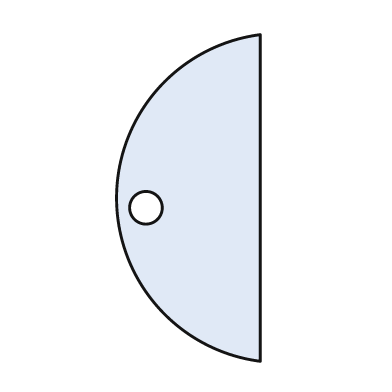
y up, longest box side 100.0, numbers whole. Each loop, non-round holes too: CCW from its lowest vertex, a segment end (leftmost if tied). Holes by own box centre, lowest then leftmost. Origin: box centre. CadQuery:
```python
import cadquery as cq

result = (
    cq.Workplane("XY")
    .moveTo(22.0, -50.0)
    .lineTo(22.0, 50.0)
    .threePointArc((-22.0, 0.0), (22.0, -50.0))
    .close()
    .moveTo(-13.0, -3.0)
    .circle(5.0)
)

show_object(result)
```